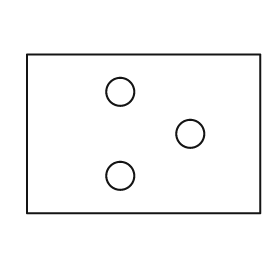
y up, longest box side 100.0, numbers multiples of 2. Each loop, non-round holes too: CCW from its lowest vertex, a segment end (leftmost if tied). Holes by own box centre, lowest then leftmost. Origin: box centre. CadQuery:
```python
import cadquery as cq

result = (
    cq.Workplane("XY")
    .moveTo(-50.0, -34.0)
    .lineTo(50.0, -34.0)
    .lineTo(50.0, 34.0)
    .lineTo(-50.0, 34.0)
    .close()
    .moveTo(-10.0, -18.0)
    .circle(6.0)
    .moveTo(20.0, 0.0)
    .circle(6.0)
    .moveTo(-10.0, 18.0)
    .circle(6.0)
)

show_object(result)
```